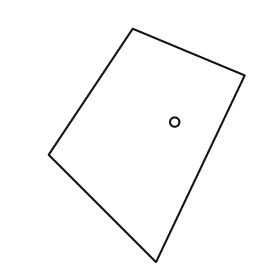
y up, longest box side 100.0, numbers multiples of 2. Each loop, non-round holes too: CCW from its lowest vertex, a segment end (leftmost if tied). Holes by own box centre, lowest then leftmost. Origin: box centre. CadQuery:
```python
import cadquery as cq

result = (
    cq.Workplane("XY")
    .moveTo(4.0, -50.0)
    .lineTo(42.0, 30.0)
    .lineTo(-6.0, 50.0)
    .lineTo(-42.0, -4.0)
    .close()
    .moveTo(12.0, 10.0)
    .circle(2.0)
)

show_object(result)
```